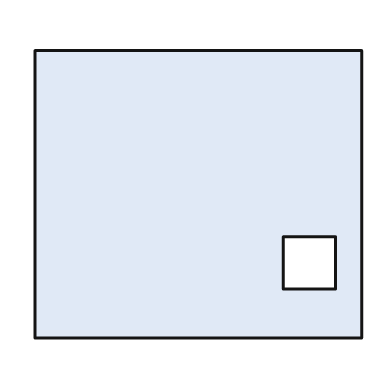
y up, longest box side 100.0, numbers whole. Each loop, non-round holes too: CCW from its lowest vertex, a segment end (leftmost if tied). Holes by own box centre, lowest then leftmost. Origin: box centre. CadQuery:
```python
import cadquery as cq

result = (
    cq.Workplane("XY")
    .moveTo(-50.0, -44.0)
    .lineTo(50.0, -44.0)
    .lineTo(50.0, 44.0)
    .lineTo(-50.0, 44.0)
    .close()
    .moveTo(26.0, -29.0)
    .lineTo(42.0, -29.0)
    .lineTo(42.0, -13.0)
    .lineTo(26.0, -13.0)
    .close()
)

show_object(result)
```